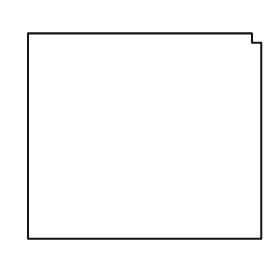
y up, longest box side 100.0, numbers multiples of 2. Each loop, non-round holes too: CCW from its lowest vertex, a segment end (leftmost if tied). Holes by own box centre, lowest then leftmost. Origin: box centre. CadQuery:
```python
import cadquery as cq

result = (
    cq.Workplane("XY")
    .moveTo(-50.0, -44.0)
    .lineTo(50.0, -44.0)
    .lineTo(50.0, 40.0)
    .lineTo(46.0, 40.0)
    .lineTo(46.0, 44.0)
    .lineTo(-50.0, 44.0)
    .close()
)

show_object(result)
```